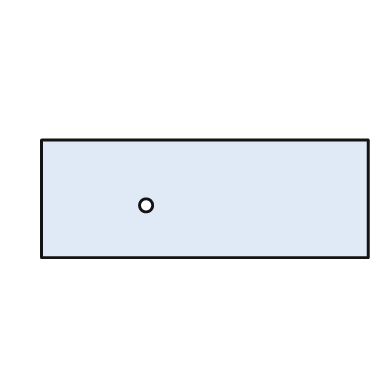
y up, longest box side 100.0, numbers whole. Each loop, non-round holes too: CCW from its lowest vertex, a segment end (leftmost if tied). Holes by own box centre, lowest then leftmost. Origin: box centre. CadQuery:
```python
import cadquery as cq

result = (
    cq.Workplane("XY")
    .moveTo(-50.0, -18.0)
    .lineTo(50.0, -18.0)
    .lineTo(50.0, 18.0)
    .lineTo(-50.0, 18.0)
    .close()
    .moveTo(-18.0, -2.0)
    .circle(2.0)
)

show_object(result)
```